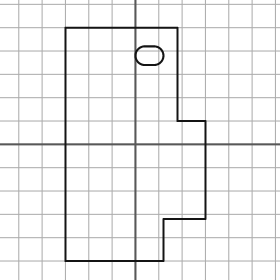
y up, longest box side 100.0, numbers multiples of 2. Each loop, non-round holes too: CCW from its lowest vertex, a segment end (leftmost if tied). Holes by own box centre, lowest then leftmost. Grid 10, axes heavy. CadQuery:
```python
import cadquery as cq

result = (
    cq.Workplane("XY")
    .moveTo(-30.0, -50.0)
    .lineTo(12.0, -50.0)
    .lineTo(12.0, -32.0)
    .lineTo(30.0, -32.0)
    .lineTo(30.0, 10.0)
    .lineTo(18.0, 10.0)
    .lineTo(18.0, 50.0)
    .lineTo(-30.0, 50.0)
    .close()
    .moveTo(4.0, 34.0)
    .lineTo(8.0, 34.0)
    .threePointArc((12.0, 38.0), (8.0, 42.0))
    .lineTo(4.0, 42.0)
    .threePointArc((0.0, 38.0), (4.0, 34.0))
    .close()
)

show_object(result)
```